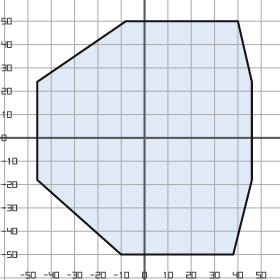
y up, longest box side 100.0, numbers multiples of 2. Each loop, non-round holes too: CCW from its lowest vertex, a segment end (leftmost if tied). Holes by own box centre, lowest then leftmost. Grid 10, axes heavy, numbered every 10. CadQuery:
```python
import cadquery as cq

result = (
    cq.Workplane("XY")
    .moveTo(-10.0, -50.0)
    .lineTo(38.0, -50.0)
    .lineTo(46.0, -18.0)
    .lineTo(46.0, 24.0)
    .lineTo(40.0, 50.0)
    .lineTo(-8.0, 50.0)
    .lineTo(-46.0, 24.0)
    .lineTo(-46.0, -18.0)
    .close()
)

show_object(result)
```